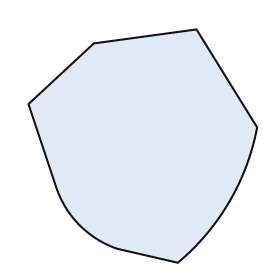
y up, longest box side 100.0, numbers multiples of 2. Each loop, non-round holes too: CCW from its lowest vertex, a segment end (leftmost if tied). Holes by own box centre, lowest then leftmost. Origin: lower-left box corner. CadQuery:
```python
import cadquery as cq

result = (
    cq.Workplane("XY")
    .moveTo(64.0, 0.0)
    .threePointArc((86.0, 26.0), (98.0, 58.0))
    .lineTo(72.0, 100.0)
    .lineTo(28.0, 94.0)
    .lineTo(0.0, 68.0)
    .lineTo(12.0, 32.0)
    .threePointArc((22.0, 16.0), (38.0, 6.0))
    .close()
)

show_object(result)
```